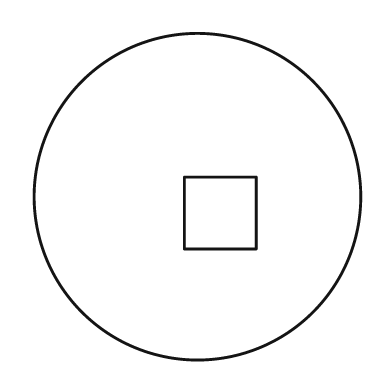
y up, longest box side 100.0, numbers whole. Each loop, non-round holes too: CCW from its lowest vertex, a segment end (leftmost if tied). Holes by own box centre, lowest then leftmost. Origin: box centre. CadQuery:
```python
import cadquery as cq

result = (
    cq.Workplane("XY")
    .moveTo(0.0, 0.0)
    .circle(50.0)
    .moveTo(-4.0, -16.0)
    .lineTo(18.0, -16.0)
    .lineTo(18.0, 6.0)
    .lineTo(-4.0, 6.0)
    .close()
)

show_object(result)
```